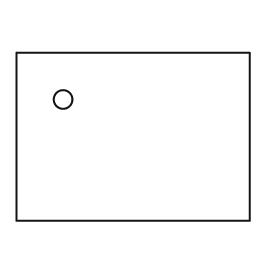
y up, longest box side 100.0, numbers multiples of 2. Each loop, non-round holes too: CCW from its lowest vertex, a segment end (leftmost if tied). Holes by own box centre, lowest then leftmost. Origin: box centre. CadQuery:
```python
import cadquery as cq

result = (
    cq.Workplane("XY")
    .moveTo(-50.0, -36.0)
    .lineTo(50.0, -36.0)
    .lineTo(50.0, 36.0)
    .lineTo(-50.0, 36.0)
    .close()
    .moveTo(-30.0, 16.0)
    .circle(4.0)
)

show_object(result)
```